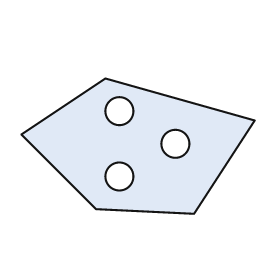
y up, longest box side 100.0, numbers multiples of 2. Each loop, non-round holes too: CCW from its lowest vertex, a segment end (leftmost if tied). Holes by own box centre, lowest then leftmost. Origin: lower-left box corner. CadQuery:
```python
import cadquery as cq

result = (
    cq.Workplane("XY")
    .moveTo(74.0, 0.0)
    .lineTo(100.0, 40.0)
    .lineTo(36.0, 58.0)
    .lineTo(0.0, 34.0)
    .lineTo(32.0, 2.0)
    .close()
    .moveTo(42.0, 16.0)
    .circle(6.0)
    .moveTo(66.0, 30.0)
    .circle(6.0)
    .moveTo(42.0, 44.0)
    .circle(6.0)
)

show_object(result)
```